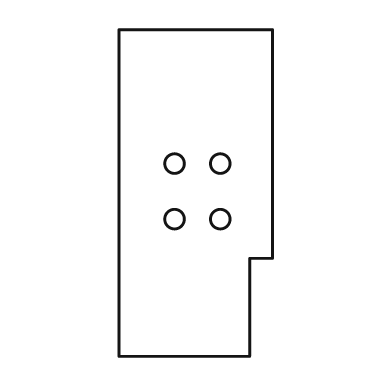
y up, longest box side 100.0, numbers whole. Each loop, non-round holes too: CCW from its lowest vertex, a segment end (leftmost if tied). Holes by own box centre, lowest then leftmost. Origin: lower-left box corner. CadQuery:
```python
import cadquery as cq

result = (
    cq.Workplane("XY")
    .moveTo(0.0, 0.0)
    .lineTo(40.0, 0.0)
    .lineTo(40.0, 30.0)
    .lineTo(47.0, 30.0)
    .lineTo(47.0, 100.0)
    .lineTo(0.0, 100.0)
    .close()
    .moveTo(17.0, 42.0)
    .circle(3.0)
    .moveTo(31.0, 42.0)
    .circle(3.0)
    .moveTo(17.0, 59.0)
    .circle(3.0)
    .moveTo(31.0, 59.0)
    .circle(3.0)
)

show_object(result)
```